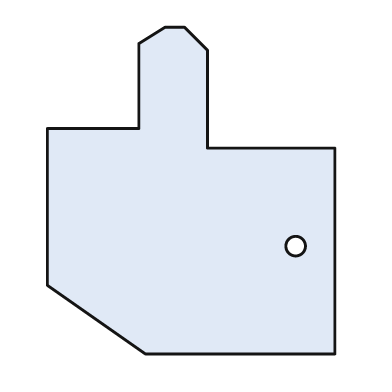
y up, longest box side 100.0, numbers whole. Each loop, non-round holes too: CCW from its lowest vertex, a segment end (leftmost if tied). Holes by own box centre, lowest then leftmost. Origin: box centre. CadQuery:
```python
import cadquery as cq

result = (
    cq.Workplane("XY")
    .moveTo(-14.0, -50.0)
    .lineTo(44.0, -50.0)
    .lineTo(44.0, 13.0)
    .lineTo(5.0, 13.0)
    .lineTo(5.0, 43.0)
    .lineTo(-2.0, 50.0)
    .lineTo(-8.0, 50.0)
    .lineTo(-16.0, 45.0)
    .lineTo(-16.0, 19.0)
    .lineTo(-44.0, 19.0)
    .lineTo(-44.0, -29.0)
    .close()
    .moveTo(32.0, -17.0)
    .circle(3.0)
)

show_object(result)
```